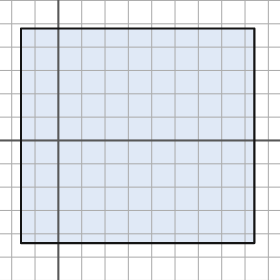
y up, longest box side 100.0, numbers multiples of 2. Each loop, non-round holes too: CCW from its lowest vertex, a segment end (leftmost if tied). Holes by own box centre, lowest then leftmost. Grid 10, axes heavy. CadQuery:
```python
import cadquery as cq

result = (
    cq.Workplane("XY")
    .moveTo(-16.0, -44.0)
    .lineTo(84.0, -44.0)
    .lineTo(84.0, 48.0)
    .lineTo(-16.0, 48.0)
    .close()
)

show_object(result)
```